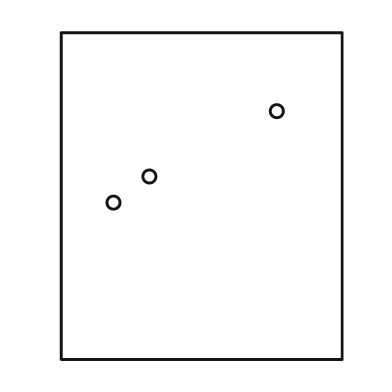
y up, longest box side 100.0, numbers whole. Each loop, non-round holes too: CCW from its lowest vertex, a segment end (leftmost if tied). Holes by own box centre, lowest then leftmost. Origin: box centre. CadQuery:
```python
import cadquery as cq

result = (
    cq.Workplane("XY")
    .moveTo(-43.0, -50.0)
    .lineTo(43.0, -50.0)
    .lineTo(43.0, 50.0)
    .lineTo(-43.0, 50.0)
    .close()
    .moveTo(-27.0, -2.0)
    .circle(2.0)
    .moveTo(-16.0, 6.0)
    .circle(2.0)
    .moveTo(23.0, 26.0)
    .circle(2.0)
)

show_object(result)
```